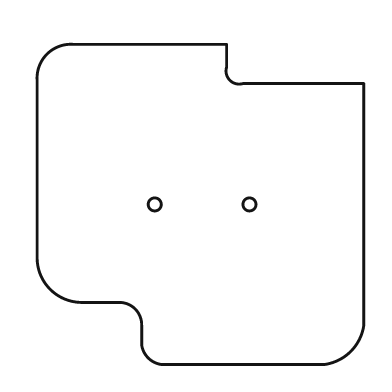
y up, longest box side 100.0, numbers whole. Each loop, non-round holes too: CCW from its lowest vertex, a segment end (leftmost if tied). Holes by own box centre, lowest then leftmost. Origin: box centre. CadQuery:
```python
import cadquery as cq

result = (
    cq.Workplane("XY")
    .moveTo(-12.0, -49.0)
    .lineTo(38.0, -49.0)
    .threePointArc((46.0, -45.0), (50.0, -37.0))
    .lineTo(50.0, 37.0)
    .lineTo(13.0, 37.0)
    .threePointArc((9.0, 38.0), (8.0, 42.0))
    .lineTo(8.0, 49.0)
    .lineTo(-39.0, 49.0)
    .threePointArc((-47.0, 46.0), (-50.0, 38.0))
    .lineTo(-50.0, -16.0)
    .threePointArc((-46.0, -26.0), (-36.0, -30.0))
    .lineTo(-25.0, -30.0)
    .threePointArc((-20.0, -32.0), (-18.0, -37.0))
    .lineTo(-18.0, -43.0)
    .threePointArc((-16.0, -47.0), (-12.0, -49.0))
    .close()
    .moveTo(-14.0, 0.0)
    .circle(2.0)
    .moveTo(15.0, 0.0)
    .circle(2.0)
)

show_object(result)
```